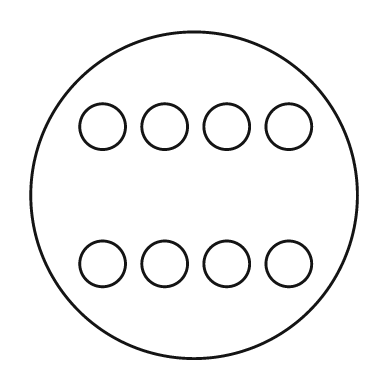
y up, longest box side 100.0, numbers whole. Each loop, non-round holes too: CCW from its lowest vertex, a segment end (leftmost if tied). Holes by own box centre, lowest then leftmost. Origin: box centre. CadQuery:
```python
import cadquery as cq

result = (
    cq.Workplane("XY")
    .moveTo(0.0, 0.0)
    .circle(50.0)
    .moveTo(-28.0, -21.0)
    .circle(7.0)
    .moveTo(-9.0, -21.0)
    .circle(7.0)
    .moveTo(10.0, -21.0)
    .circle(7.0)
    .moveTo(29.0, -21.0)
    .circle(7.0)
    .moveTo(-28.0, 21.0)
    .circle(7.0)
    .moveTo(-9.0, 21.0)
    .circle(7.0)
    .moveTo(10.0, 21.0)
    .circle(7.0)
    .moveTo(29.0, 21.0)
    .circle(7.0)
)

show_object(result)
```